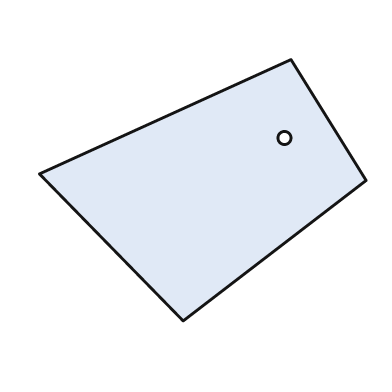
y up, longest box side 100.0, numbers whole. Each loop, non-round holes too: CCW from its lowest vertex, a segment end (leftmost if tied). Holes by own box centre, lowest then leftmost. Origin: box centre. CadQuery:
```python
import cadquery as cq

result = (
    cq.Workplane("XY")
    .moveTo(-6.0, -40.0)
    .lineTo(50.0, 3.0)
    .lineTo(27.0, 40.0)
    .lineTo(-50.0, 5.0)
    .close()
    .moveTo(25.0, 16.0)
    .circle(2.0)
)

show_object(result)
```